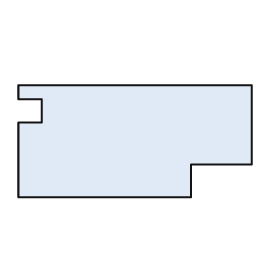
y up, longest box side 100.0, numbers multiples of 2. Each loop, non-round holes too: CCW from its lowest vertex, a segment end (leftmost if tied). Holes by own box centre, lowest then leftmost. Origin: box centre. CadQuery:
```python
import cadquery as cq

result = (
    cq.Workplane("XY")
    .moveTo(-50.0, -24.0)
    .lineTo(24.0, -24.0)
    .lineTo(24.0, -10.0)
    .lineTo(50.0, -10.0)
    .lineTo(50.0, 24.0)
    .lineTo(-50.0, 24.0)
    .lineTo(-50.0, 18.0)
    .lineTo(-40.0, 18.0)
    .lineTo(-40.0, 8.0)
    .lineTo(-50.0, 8.0)
    .close()
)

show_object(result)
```